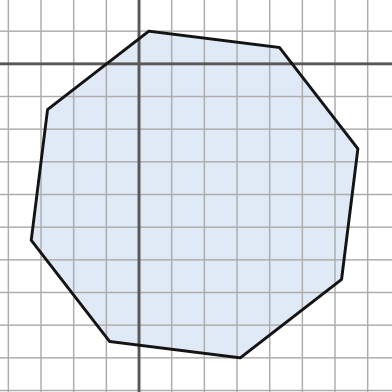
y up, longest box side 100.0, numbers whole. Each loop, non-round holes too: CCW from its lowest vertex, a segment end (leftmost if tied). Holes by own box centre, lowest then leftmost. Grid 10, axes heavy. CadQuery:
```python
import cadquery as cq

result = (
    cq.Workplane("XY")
    .moveTo(31.0, -90.0)
    .lineTo(62.0, -66.0)
    .lineTo(67.0, -26.0)
    .lineTo(43.0, 5.0)
    .lineTo(3.0, 10.0)
    .lineTo(-28.0, -14.0)
    .lineTo(-33.0, -54.0)
    .lineTo(-9.0, -85.0)
    .close()
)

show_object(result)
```